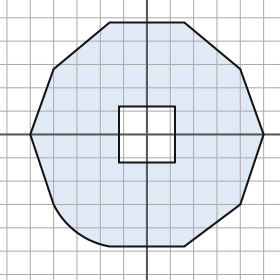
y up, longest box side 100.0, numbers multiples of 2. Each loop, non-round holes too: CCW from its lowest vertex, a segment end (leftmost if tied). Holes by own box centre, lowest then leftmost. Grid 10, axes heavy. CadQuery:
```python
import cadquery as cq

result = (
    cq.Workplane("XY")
    .moveTo(-16.0, -48.0)
    .lineTo(16.0, -48.0)
    .lineTo(40.0, -30.0)
    .lineTo(50.0, 0.0)
    .lineTo(40.0, 28.0)
    .lineTo(16.0, 48.0)
    .lineTo(-16.0, 48.0)
    .lineTo(-40.0, 28.0)
    .lineTo(-50.0, 0.0)
    .lineTo(-40.0, -30.0)
    .threePointArc((-30.0, -42.0), (-16.0, -48.0))
    .close()
    .moveTo(-12.0, -12.0)
    .lineTo(12.0, -12.0)
    .lineTo(12.0, 12.0)
    .lineTo(-12.0, 12.0)
    .close()
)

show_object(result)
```